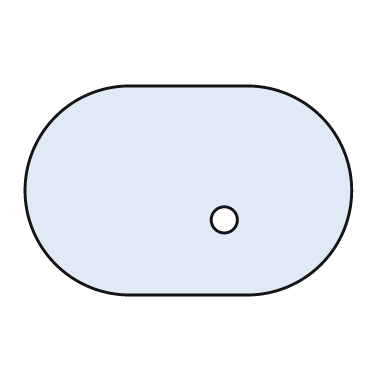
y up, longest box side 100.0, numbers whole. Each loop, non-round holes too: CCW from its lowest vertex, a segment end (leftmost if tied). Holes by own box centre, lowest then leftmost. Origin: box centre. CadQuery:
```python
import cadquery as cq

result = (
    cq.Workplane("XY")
    .moveTo(-18.0, -32.0)
    .lineTo(18.0, -32.0)
    .threePointArc((50.0, 0.0), (18.0, 32.0))
    .lineTo(-18.0, 32.0)
    .threePointArc((-50.0, 0.0), (-18.0, -32.0))
    .close()
    .moveTo(11.0, -9.0)
    .circle(4.0)
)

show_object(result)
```